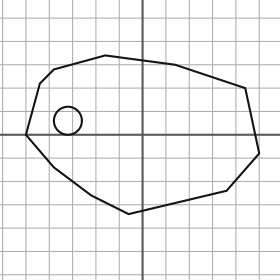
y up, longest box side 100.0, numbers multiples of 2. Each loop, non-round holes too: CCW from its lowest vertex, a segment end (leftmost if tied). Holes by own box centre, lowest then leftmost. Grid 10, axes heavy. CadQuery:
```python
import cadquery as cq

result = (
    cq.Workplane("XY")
    .moveTo(-6.0, -34.0)
    .lineTo(36.0, -24.0)
    .lineTo(50.0, -8.0)
    .lineTo(44.0, 20.0)
    .lineTo(14.0, 30.0)
    .lineTo(-16.0, 34.0)
    .lineTo(-38.0, 28.0)
    .lineTo(-44.0, 22.0)
    .lineTo(-50.0, 0.0)
    .lineTo(-38.0, -14.0)
    .lineTo(-22.0, -26.0)
    .close()
    .moveTo(-32.0, 6.0)
    .circle(6.0)
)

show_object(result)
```